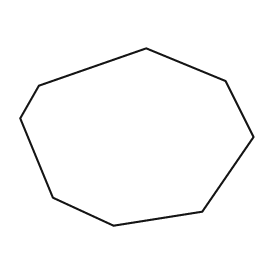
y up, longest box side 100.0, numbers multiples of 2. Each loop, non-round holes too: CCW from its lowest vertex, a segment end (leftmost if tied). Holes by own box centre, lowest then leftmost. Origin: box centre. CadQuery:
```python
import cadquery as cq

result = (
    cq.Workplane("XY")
    .moveTo(-10.0, -38.0)
    .lineTo(28.0, -32.0)
    .lineTo(50.0, 0.0)
    .lineTo(38.0, 24.0)
    .lineTo(4.0, 38.0)
    .lineTo(-42.0, 22.0)
    .lineTo(-50.0, 8.0)
    .lineTo(-36.0, -26.0)
    .close()
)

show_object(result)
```